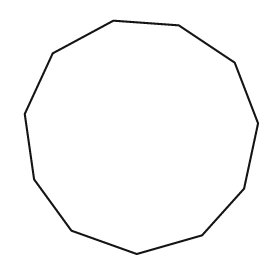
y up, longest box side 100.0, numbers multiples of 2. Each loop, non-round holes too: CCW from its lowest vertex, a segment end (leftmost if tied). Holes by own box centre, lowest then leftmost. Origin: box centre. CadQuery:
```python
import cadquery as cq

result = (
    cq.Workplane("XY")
    .moveTo(-2.0, -50.0)
    .lineTo(26.0, -42.0)
    .lineTo(44.0, -22.0)
    .lineTo(50.0, 6.0)
    .lineTo(40.0, 32.0)
    .lineTo(16.0, 48.0)
    .lineTo(-12.0, 50.0)
    .lineTo(-38.0, 36.0)
    .lineTo(-50.0, 10.0)
    .lineTo(-46.0, -18.0)
    .lineTo(-30.0, -40.0)
    .close()
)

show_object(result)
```